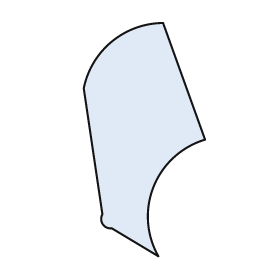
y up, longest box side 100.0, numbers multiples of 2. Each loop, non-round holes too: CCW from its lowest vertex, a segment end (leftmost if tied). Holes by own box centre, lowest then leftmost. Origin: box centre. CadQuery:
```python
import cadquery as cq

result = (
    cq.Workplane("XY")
    .moveTo(6.0, -50.0)
    .threePointArc((4.0, -20.0), (26.0, 0.0))
    .lineTo(8.0, 50.0)
    .threePointArc((-14.0, 42.0), (-26.0, 22.0))
    .lineTo(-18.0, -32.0)
    .threePointArc((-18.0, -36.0), (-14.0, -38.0))
    .close()
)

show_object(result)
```